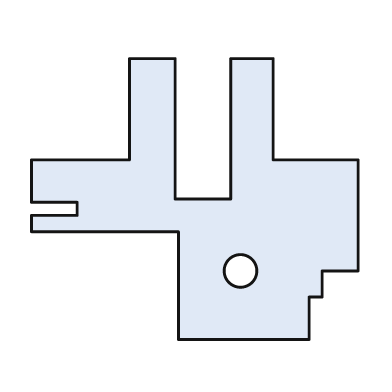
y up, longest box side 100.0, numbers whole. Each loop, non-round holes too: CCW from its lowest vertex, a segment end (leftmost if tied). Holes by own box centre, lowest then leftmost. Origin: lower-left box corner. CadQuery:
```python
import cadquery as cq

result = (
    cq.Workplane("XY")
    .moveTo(45.0, 0.0)
    .lineTo(85.0, 0.0)
    .lineTo(85.0, 13.0)
    .lineTo(89.0, 13.0)
    .lineTo(89.0, 21.0)
    .lineTo(100.0, 21.0)
    .lineTo(100.0, 55.0)
    .lineTo(74.0, 55.0)
    .lineTo(74.0, 86.0)
    .lineTo(61.0, 86.0)
    .lineTo(61.0, 43.0)
    .lineTo(44.0, 43.0)
    .lineTo(44.0, 86.0)
    .lineTo(30.0, 86.0)
    .lineTo(30.0, 55.0)
    .lineTo(0.0, 55.0)
    .lineTo(0.0, 42.0)
    .lineTo(14.0, 42.0)
    .lineTo(14.0, 38.0)
    .lineTo(0.0, 38.0)
    .lineTo(0.0, 33.0)
    .lineTo(45.0, 33.0)
    .close()
    .moveTo(64.0, 21.0)
    .circle(5.0)
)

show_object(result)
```